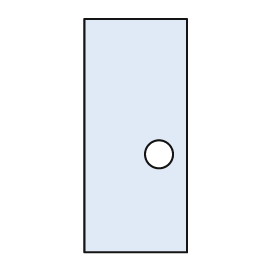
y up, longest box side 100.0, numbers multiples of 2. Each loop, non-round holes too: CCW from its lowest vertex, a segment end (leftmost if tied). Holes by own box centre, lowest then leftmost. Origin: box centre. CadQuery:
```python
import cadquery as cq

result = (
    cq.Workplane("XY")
    .moveTo(-22.0, -50.0)
    .lineTo(22.0, -50.0)
    .lineTo(22.0, 50.0)
    .lineTo(-22.0, 50.0)
    .close()
    .moveTo(10.0, -8.0)
    .circle(6.0)
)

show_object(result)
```